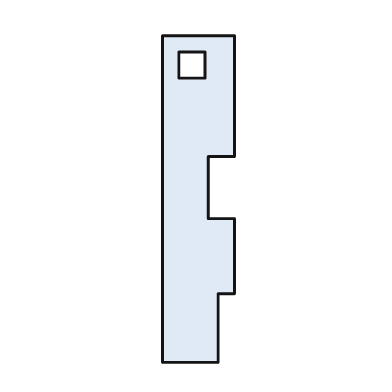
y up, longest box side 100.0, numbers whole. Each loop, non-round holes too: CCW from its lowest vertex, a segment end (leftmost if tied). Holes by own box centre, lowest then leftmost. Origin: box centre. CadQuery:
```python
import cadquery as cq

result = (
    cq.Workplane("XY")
    .moveTo(-11.0, -50.0)
    .lineTo(6.0, -50.0)
    .lineTo(6.0, -29.0)
    .lineTo(11.0, -29.0)
    .lineTo(11.0, -6.0)
    .lineTo(3.0, -6.0)
    .lineTo(3.0, 13.0)
    .lineTo(11.0, 13.0)
    .lineTo(11.0, 50.0)
    .lineTo(-11.0, 50.0)
    .close()
    .moveTo(-6.0, 37.0)
    .lineTo(2.0, 37.0)
    .lineTo(2.0, 45.0)
    .lineTo(-6.0, 45.0)
    .close()
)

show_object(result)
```